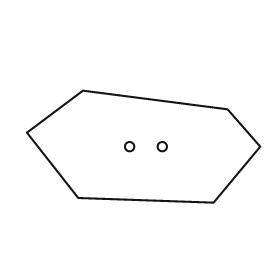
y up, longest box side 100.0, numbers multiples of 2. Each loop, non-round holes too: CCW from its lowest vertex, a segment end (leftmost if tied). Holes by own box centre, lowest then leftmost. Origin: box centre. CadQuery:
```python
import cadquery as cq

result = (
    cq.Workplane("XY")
    .moveTo(30.0, -24.0)
    .lineTo(50.0, 0.0)
    .lineTo(36.0, 16.0)
    .lineTo(-26.0, 24.0)
    .lineTo(-50.0, 6.0)
    .lineTo(-28.0, -22.0)
    .close()
    .moveTo(-6.0, 0.0)
    .circle(2.0)
    .moveTo(8.0, 0.0)
    .circle(2.0)
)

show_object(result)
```